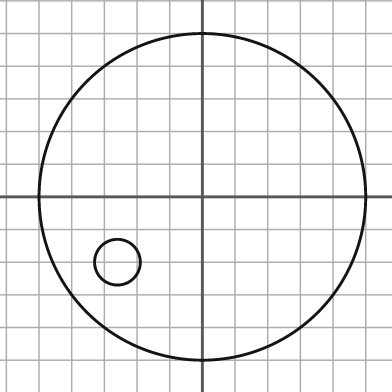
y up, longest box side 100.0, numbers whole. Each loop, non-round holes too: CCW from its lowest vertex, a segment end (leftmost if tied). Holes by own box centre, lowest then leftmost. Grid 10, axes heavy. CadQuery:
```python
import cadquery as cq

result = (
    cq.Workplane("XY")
    .moveTo(0.0, 0.0)
    .circle(50.0)
    .moveTo(-26.0, -20.0)
    .circle(7.0)
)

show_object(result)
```